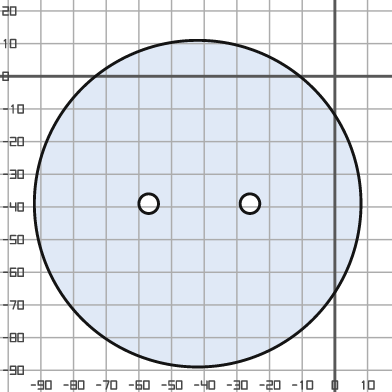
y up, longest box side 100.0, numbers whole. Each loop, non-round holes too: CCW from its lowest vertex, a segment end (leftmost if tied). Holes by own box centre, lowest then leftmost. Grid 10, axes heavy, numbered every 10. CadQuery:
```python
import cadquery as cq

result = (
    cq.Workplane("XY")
    .moveTo(-42.0, -39.0)
    .circle(50.0)
    .moveTo(-57.0, -39.0)
    .circle(3.0)
    .moveTo(-26.0, -39.0)
    .circle(3.0)
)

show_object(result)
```